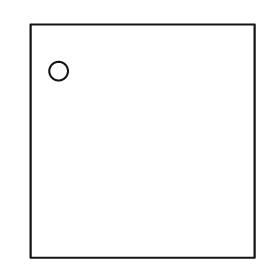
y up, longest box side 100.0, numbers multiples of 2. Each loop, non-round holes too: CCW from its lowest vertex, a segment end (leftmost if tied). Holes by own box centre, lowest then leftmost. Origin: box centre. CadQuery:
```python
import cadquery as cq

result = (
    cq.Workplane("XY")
    .moveTo(-48.0, -50.0)
    .lineTo(48.0, -50.0)
    .lineTo(48.0, 50.0)
    .lineTo(-48.0, 50.0)
    .close()
    .moveTo(-36.0, 30.0)
    .circle(4.0)
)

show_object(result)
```